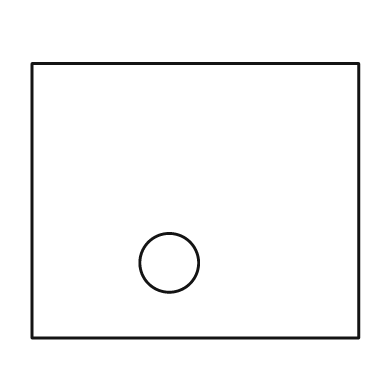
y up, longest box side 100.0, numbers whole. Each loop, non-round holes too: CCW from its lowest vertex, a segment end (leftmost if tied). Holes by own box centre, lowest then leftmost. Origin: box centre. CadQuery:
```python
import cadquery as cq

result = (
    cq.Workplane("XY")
    .moveTo(-50.0, -42.0)
    .lineTo(50.0, -42.0)
    .lineTo(50.0, 42.0)
    .lineTo(-50.0, 42.0)
    .close()
    .moveTo(-8.0, -19.0)
    .circle(9.0)
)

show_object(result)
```